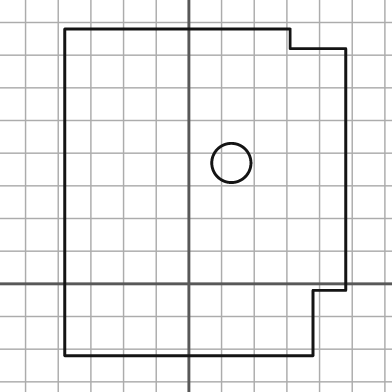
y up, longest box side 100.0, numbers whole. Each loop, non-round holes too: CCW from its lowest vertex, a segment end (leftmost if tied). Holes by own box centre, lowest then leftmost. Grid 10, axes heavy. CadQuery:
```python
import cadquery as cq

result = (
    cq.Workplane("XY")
    .moveTo(-38.0, -22.0)
    .lineTo(38.0, -22.0)
    .lineTo(38.0, -2.0)
    .lineTo(48.0, -2.0)
    .lineTo(48.0, 72.0)
    .lineTo(31.0, 72.0)
    .lineTo(31.0, 78.0)
    .lineTo(-38.0, 78.0)
    .close()
    .moveTo(13.0, 37.0)
    .circle(6.0)
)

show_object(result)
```